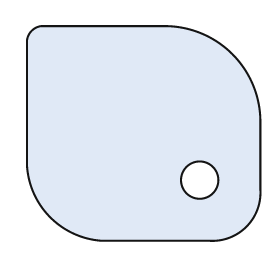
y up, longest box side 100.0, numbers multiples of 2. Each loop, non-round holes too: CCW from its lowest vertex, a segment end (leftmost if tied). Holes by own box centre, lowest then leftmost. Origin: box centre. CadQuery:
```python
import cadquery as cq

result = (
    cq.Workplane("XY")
    .moveTo(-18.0, -46.0)
    .lineTo(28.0, -46.0)
    .threePointArc((44.0, -40.0), (50.0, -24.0))
    .lineTo(50.0, 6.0)
    .threePointArc((38.0, 34.0), (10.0, 46.0))
    .lineTo(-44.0, 46.0)
    .threePointArc((-48.0, 44.0), (-50.0, 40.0))
    .lineTo(-50.0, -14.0)
    .threePointArc((-40.0, -36.0), (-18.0, -46.0))
    .close()
    .moveTo(24.0, -20.0)
    .circle(8.0)
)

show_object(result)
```